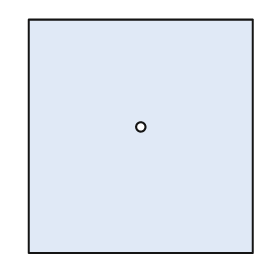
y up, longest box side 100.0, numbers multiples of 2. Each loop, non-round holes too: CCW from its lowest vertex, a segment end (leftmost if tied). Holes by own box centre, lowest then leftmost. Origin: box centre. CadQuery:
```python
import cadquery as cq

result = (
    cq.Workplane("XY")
    .moveTo(-48.0, -50.0)
    .lineTo(48.0, -50.0)
    .lineTo(48.0, 50.0)
    .lineTo(-48.0, 50.0)
    .close()
    .moveTo(0.0, 4.0)
    .circle(2.0)
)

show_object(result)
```